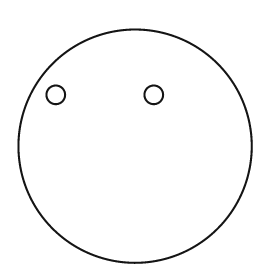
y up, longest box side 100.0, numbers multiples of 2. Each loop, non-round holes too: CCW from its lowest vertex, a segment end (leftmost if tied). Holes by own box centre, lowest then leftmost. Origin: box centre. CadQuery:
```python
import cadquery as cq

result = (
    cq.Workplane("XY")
    .moveTo(0.0, 0.0)
    .circle(50.0)
    .moveTo(-34.0, 22.0)
    .circle(4.0)
    .moveTo(8.0, 22.0)
    .circle(4.0)
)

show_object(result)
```